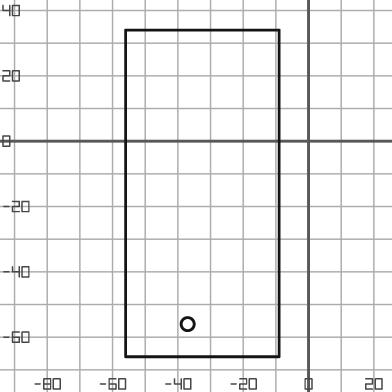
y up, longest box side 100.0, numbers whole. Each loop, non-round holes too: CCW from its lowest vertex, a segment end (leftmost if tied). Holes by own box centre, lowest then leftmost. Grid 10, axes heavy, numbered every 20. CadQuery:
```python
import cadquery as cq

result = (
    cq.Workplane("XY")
    .moveTo(-56.0, -66.0)
    .lineTo(-9.0, -66.0)
    .lineTo(-9.0, 34.0)
    .lineTo(-56.0, 34.0)
    .close()
    .moveTo(-37.0, -56.0)
    .circle(2.0)
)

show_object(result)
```